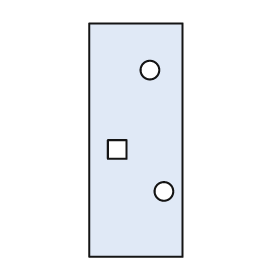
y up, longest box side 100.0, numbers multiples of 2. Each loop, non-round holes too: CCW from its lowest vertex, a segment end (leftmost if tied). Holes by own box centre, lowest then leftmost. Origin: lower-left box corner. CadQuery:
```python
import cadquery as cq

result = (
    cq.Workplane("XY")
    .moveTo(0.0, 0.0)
    .lineTo(40.0, 0.0)
    .lineTo(40.0, 100.0)
    .lineTo(0.0, 100.0)
    .close()
    .moveTo(32.0, 28.0)
    .circle(4.0)
    .moveTo(8.0, 42.0)
    .lineTo(16.0, 42.0)
    .lineTo(16.0, 50.0)
    .lineTo(8.0, 50.0)
    .close()
    .moveTo(26.0, 80.0)
    .circle(4.0)
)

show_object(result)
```